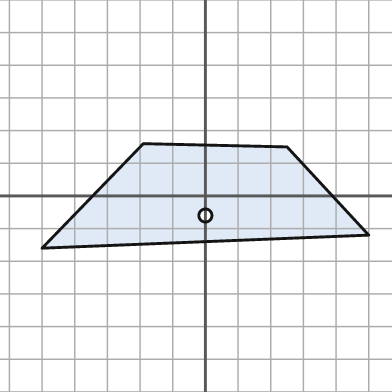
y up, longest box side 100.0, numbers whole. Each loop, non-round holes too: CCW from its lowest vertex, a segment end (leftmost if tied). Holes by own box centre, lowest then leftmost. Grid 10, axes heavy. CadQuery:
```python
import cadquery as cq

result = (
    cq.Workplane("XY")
    .moveTo(-50.0, -16.0)
    .lineTo(50.0, -12.0)
    .lineTo(25.0, 15.0)
    .lineTo(-19.0, 16.0)
    .close()
    .moveTo(0.0, -6.0)
    .circle(2.0)
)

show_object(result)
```